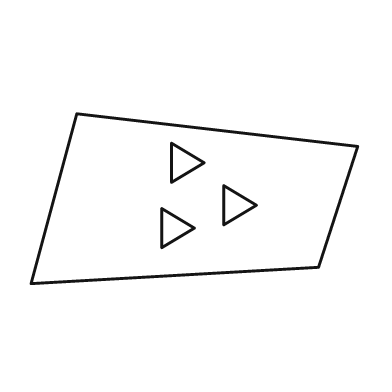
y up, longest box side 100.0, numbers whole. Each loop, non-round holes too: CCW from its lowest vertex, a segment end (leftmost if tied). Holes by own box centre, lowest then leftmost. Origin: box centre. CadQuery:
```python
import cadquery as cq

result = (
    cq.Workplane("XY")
    .moveTo(-50.0, -26.0)
    .lineTo(38.0, -21.0)
    .lineTo(50.0, 16.0)
    .lineTo(-36.0, 26.0)
    .close()
    .moveTo(-10.0, -15.0)
    .lineTo(0.0, -9.0)
    .lineTo(-10.0, -3.0)
    .close()
    .moveTo(9.0, -8.0)
    .lineTo(19.0, -2.0)
    .lineTo(9.0, 4.0)
    .close()
    .moveTo(-7.0, 5.0)
    .lineTo(3.0, 11.0)
    .lineTo(-7.0, 17.0)
    .close()
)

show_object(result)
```